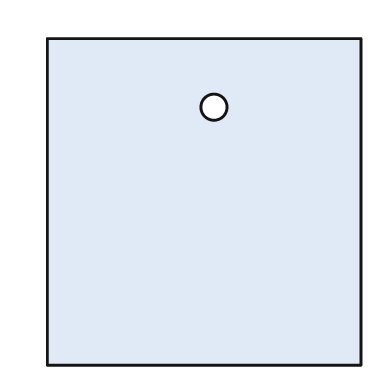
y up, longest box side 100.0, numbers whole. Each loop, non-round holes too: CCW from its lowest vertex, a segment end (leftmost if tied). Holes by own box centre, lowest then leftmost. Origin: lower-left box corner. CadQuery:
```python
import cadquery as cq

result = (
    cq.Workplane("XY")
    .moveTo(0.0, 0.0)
    .lineTo(96.0, 0.0)
    .lineTo(96.0, 100.0)
    .lineTo(0.0, 100.0)
    .close()
    .moveTo(51.0, 79.0)
    .circle(4.0)
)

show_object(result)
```